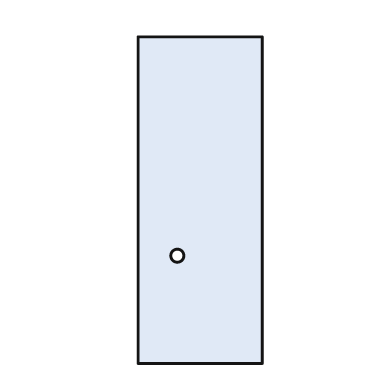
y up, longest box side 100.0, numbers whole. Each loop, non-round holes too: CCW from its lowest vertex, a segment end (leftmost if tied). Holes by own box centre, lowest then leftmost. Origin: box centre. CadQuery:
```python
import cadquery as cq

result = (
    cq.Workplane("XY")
    .moveTo(-19.0, -50.0)
    .lineTo(19.0, -50.0)
    .lineTo(19.0, 50.0)
    .lineTo(-19.0, 50.0)
    .close()
    .moveTo(-7.0, -17.0)
    .circle(2.0)
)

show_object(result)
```